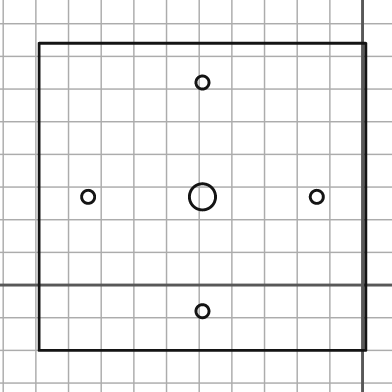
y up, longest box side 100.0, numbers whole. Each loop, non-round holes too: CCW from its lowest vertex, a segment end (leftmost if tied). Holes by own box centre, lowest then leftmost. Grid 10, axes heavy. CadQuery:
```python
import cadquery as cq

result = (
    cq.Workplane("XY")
    .moveTo(-99.0, -20.0)
    .lineTo(1.0, -20.0)
    .lineTo(1.0, 74.0)
    .lineTo(-99.0, 74.0)
    .close()
    .moveTo(-49.0, -8.0)
    .circle(2.0)
    .moveTo(-84.0, 27.0)
    .circle(2.0)
    .moveTo(-49.0, 27.0)
    .circle(4.0)
    .moveTo(-14.0, 27.0)
    .circle(2.0)
    .moveTo(-49.0, 62.0)
    .circle(2.0)
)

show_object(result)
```